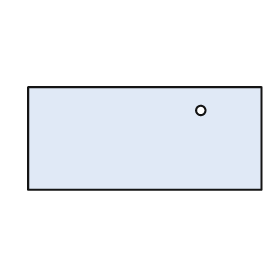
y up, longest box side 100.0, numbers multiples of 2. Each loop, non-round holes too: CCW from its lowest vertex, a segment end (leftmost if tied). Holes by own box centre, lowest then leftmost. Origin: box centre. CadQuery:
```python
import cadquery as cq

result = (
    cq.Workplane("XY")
    .moveTo(-50.0, -22.0)
    .lineTo(50.0, -22.0)
    .lineTo(50.0, 22.0)
    .lineTo(-50.0, 22.0)
    .close()
    .moveTo(24.0, 12.0)
    .circle(2.0)
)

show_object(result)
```